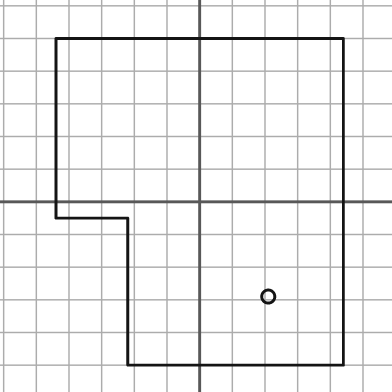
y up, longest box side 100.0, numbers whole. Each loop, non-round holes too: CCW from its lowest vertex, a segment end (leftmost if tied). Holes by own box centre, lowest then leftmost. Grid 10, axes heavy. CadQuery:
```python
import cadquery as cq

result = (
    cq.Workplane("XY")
    .moveTo(-22.0, -50.0)
    .lineTo(44.0, -50.0)
    .lineTo(44.0, 50.0)
    .lineTo(-44.0, 50.0)
    .lineTo(-44.0, -5.0)
    .lineTo(-22.0, -5.0)
    .close()
    .moveTo(21.0, -29.0)
    .circle(2.0)
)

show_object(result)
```